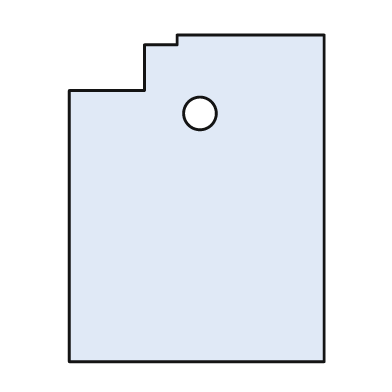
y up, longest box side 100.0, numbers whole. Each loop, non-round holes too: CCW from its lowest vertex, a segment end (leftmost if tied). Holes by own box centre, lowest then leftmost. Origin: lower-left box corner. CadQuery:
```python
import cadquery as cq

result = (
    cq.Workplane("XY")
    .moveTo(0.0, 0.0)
    .lineTo(78.0, 0.0)
    .lineTo(78.0, 100.0)
    .lineTo(33.0, 100.0)
    .lineTo(33.0, 97.0)
    .lineTo(23.0, 97.0)
    .lineTo(23.0, 83.0)
    .lineTo(0.0, 83.0)
    .close()
    .moveTo(40.0, 76.0)
    .circle(5.0)
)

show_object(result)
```